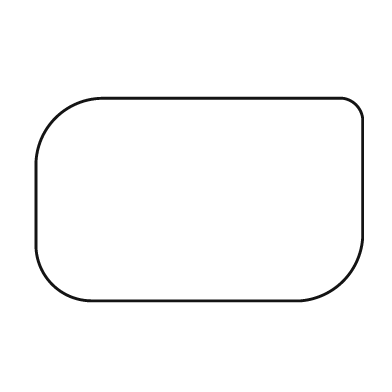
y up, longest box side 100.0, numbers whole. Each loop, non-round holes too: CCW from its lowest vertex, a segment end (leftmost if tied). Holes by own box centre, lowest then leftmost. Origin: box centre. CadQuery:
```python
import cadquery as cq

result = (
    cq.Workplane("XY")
    .moveTo(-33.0, -31.0)
    .lineTo(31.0, -31.0)
    .threePointArc((44.0, -25.0), (50.0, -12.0))
    .lineTo(50.0, 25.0)
    .threePointArc((48.0, 29.0), (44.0, 31.0))
    .lineTo(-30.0, 31.0)
    .threePointArc((-44.0, 25.0), (-50.0, 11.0))
    .lineTo(-50.0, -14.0)
    .threePointArc((-45.0, -26.0), (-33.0, -31.0))
    .close()
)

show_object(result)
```